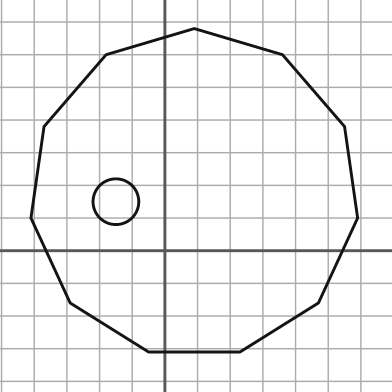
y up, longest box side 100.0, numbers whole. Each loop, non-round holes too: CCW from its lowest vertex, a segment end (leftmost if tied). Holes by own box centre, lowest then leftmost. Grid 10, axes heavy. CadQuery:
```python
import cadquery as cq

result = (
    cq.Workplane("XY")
    .moveTo(-5.0, -31.0)
    .lineTo(23.0, -31.0)
    .lineTo(47.0, -16.0)
    .lineTo(59.0, 10.0)
    .lineTo(55.0, 38.0)
    .lineTo(36.0, 60.0)
    .lineTo(9.0, 68.0)
    .lineTo(-18.0, 60.0)
    .lineTo(-37.0, 38.0)
    .lineTo(-41.0, 10.0)
    .lineTo(-29.0, -16.0)
    .close()
    .moveTo(-15.0, 15.0)
    .circle(7.0)
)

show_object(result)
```